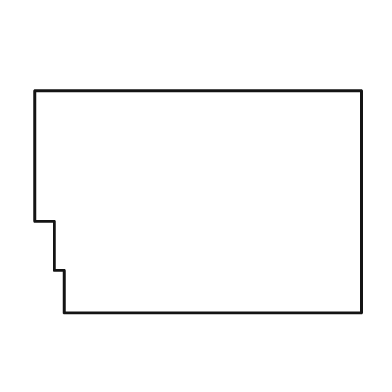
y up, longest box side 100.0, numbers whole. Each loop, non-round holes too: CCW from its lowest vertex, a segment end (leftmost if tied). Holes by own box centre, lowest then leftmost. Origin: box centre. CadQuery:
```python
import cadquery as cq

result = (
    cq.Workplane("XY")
    .moveTo(-41.0, -34.0)
    .lineTo(50.0, -34.0)
    .lineTo(50.0, 34.0)
    .lineTo(-50.0, 34.0)
    .lineTo(-50.0, -6.0)
    .lineTo(-44.0, -6.0)
    .lineTo(-44.0, -21.0)
    .lineTo(-41.0, -21.0)
    .close()
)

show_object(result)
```